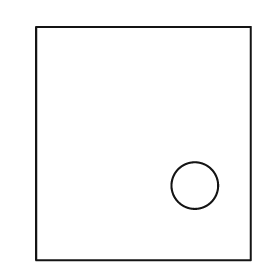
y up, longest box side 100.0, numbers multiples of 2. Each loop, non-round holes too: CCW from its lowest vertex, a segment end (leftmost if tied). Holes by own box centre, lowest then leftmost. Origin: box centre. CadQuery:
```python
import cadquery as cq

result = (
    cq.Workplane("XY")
    .moveTo(-46.0, -50.0)
    .lineTo(46.0, -50.0)
    .lineTo(46.0, 50.0)
    .lineTo(-46.0, 50.0)
    .close()
    .moveTo(22.0, -18.0)
    .circle(10.0)
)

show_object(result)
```